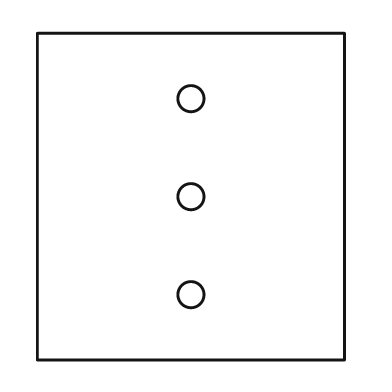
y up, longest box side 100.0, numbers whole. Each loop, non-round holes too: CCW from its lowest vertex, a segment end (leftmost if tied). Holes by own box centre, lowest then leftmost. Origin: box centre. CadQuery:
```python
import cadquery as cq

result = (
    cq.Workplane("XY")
    .moveTo(-47.0, -50.0)
    .lineTo(47.0, -50.0)
    .lineTo(47.0, 50.0)
    .lineTo(-47.0, 50.0)
    .close()
    .moveTo(0.0, -30.0)
    .circle(4.0)
    .moveTo(0.0, 0.0)
    .circle(4.0)
    .moveTo(0.0, 30.0)
    .circle(4.0)
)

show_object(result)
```